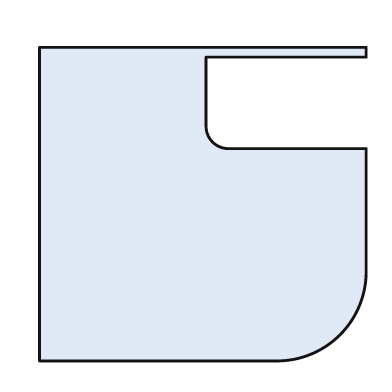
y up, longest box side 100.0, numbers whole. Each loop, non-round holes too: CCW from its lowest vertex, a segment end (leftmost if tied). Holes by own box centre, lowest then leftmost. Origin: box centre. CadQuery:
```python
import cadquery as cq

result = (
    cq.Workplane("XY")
    .moveTo(-50.0, -48.0)
    .lineTo(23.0, -48.0)
    .threePointArc((42.0, -40.0), (50.0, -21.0))
    .lineTo(50.0, 17.0)
    .lineTo(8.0, 17.0)
    .threePointArc((3.0, 19.0), (1.0, 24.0))
    .lineTo(1.0, 45.0)
    .lineTo(50.0, 45.0)
    .lineTo(50.0, 48.0)
    .lineTo(-50.0, 48.0)
    .close()
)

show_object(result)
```